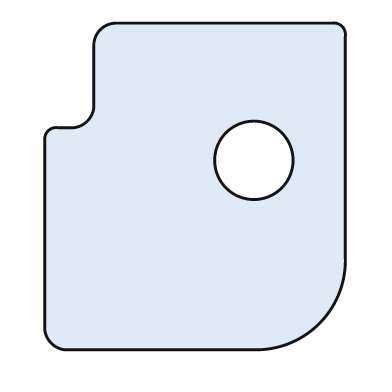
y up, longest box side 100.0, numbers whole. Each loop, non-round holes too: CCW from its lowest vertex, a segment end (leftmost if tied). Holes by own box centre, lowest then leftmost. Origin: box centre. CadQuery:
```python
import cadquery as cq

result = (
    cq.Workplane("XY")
    .moveTo(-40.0, -50.0)
    .lineTo(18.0, -50.0)
    .threePointArc((38.0, -42.0), (46.0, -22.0))
    .lineTo(46.0, 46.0)
    .threePointArc((45.0, 49.0), (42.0, 50.0))
    .lineTo(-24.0, 50.0)
    .threePointArc((-29.0, 48.0), (-31.0, 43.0))
    .lineTo(-31.0, 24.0)
    .threePointArc((-33.0, 20.0), (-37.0, 18.0))
    .lineTo(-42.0, 18.0)
    .threePointArc((-45.0, 17.0), (-46.0, 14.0))
    .lineTo(-46.0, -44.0)
    .threePointArc((-44.0, -48.0), (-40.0, -50.0))
    .close()
    .moveTo(18.0, 8.0)
    .circle(12.0)
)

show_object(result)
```